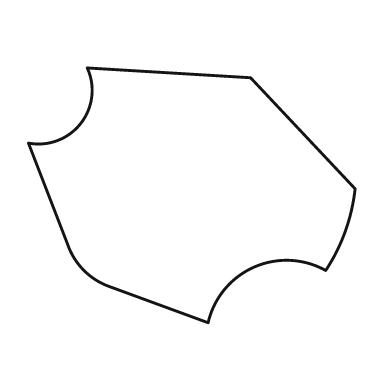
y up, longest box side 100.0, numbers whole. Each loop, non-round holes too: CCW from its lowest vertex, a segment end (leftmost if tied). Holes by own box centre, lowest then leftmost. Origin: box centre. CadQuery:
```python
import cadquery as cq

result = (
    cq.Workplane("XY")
    .moveTo(5.0, -39.0)
    .threePointArc((19.0, -22.0), (41.0, -23.0))
    .threePointArc((47.0, -11.0), (50.0, 2.0))
    .lineTo(18.0, 36.0)
    .lineTo(-32.0, 39.0)
    .threePointArc((-34.0, 22.0), (-50.0, 16.0))
    .lineTo(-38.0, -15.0)
    .threePointArc((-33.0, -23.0), (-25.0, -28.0))
    .close()
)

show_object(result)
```